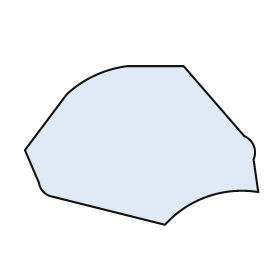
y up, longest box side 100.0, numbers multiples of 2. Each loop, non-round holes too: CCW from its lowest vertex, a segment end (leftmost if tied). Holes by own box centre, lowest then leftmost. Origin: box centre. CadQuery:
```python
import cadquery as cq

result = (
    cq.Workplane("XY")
    .moveTo(10.0, -34.0)
    .threePointArc((28.0, -22.0), (50.0, -20.0))
    .lineTo(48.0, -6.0)
    .threePointArc((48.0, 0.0), (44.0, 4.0))
    .lineTo(18.0, 34.0)
    .lineTo(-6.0, 34.0)
    .threePointArc((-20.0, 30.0), (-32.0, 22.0))
    .lineTo(-50.0, -2.0)
    .lineTo(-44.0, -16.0)
    .threePointArc((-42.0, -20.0), (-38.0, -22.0))
    .close()
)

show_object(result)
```